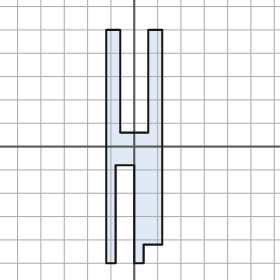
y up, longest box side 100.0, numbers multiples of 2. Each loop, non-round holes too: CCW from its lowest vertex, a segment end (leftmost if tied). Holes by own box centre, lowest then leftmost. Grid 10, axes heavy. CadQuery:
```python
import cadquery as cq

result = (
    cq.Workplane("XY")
    .moveTo(-12.0, -50.0)
    .lineTo(-8.0, -50.0)
    .lineTo(-8.0, -8.0)
    .lineTo(0.0, -8.0)
    .lineTo(0.0, -50.0)
    .lineTo(4.0, -50.0)
    .lineTo(4.0, -42.0)
    .lineTo(12.0, -42.0)
    .lineTo(12.0, 50.0)
    .lineTo(6.0, 50.0)
    .lineTo(6.0, 6.0)
    .lineTo(-6.0, 6.0)
    .lineTo(-6.0, 50.0)
    .lineTo(-12.0, 50.0)
    .close()
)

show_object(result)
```